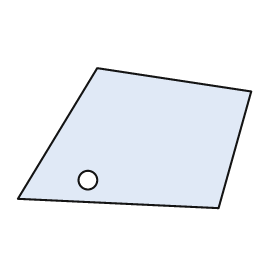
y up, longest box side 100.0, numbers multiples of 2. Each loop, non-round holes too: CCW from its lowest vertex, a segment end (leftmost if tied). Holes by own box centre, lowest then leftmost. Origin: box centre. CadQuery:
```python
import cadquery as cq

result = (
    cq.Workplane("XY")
    .moveTo(36.0, -30.0)
    .lineTo(50.0, 20.0)
    .lineTo(-16.0, 30.0)
    .lineTo(-50.0, -26.0)
    .close()
    .moveTo(-20.0, -18.0)
    .circle(4.0)
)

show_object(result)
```